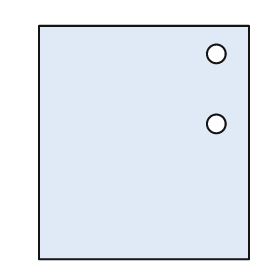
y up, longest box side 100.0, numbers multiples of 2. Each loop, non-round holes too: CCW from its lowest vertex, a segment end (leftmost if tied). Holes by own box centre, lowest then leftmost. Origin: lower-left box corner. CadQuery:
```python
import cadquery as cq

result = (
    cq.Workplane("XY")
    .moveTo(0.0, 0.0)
    .lineTo(90.0, 0.0)
    .lineTo(90.0, 100.0)
    .lineTo(0.0, 100.0)
    .close()
    .moveTo(76.0, 58.0)
    .circle(4.0)
    .moveTo(76.0, 88.0)
    .circle(4.0)
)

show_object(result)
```